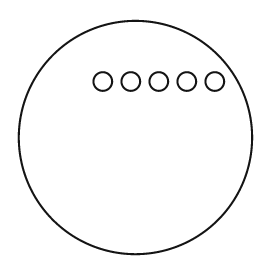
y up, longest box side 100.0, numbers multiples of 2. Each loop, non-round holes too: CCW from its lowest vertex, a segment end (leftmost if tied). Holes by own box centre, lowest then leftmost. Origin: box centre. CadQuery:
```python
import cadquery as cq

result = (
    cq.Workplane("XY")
    .moveTo(0.0, 0.0)
    .circle(50.0)
    .moveTo(-14.0, 24.0)
    .circle(4.0)
    .moveTo(-2.0, 24.0)
    .circle(4.0)
    .moveTo(10.0, 24.0)
    .circle(4.0)
    .moveTo(22.0, 24.0)
    .circle(4.0)
    .moveTo(34.0, 24.0)
    .circle(4.0)
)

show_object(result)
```